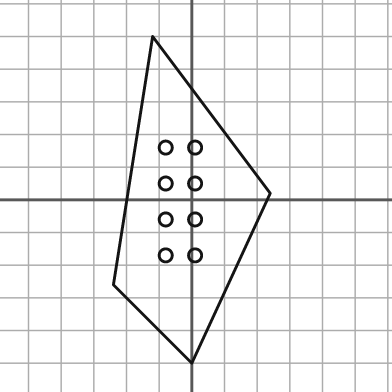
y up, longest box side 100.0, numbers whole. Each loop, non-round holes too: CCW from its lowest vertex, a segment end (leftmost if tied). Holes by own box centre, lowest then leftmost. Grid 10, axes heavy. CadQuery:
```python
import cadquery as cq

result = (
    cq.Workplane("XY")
    .moveTo(0.0, -50.0)
    .lineTo(24.0, 2.0)
    .lineTo(-12.0, 50.0)
    .lineTo(-24.0, -26.0)
    .close()
    .moveTo(-8.0, -17.0)
    .circle(2.0)
    .moveTo(1.0, -17.0)
    .circle(2.0)
    .moveTo(-8.0, -6.0)
    .circle(2.0)
    .moveTo(1.0, -6.0)
    .circle(2.0)
    .moveTo(-8.0, 5.0)
    .circle(2.0)
    .moveTo(1.0, 5.0)
    .circle(2.0)
    .moveTo(-8.0, 16.0)
    .circle(2.0)
    .moveTo(1.0, 16.0)
    .circle(2.0)
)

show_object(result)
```